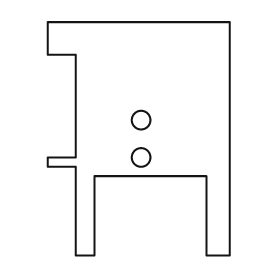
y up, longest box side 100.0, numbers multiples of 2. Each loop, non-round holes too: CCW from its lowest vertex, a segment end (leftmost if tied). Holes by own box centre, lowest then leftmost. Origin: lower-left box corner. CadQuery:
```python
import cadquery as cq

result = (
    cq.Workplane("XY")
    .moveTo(12.0, 0.0)
    .lineTo(20.0, 0.0)
    .lineTo(20.0, 34.0)
    .lineTo(68.0, 34.0)
    .lineTo(68.0, 0.0)
    .lineTo(78.0, 0.0)
    .lineTo(78.0, 100.0)
    .lineTo(0.0, 100.0)
    .lineTo(0.0, 86.0)
    .lineTo(12.0, 86.0)
    .lineTo(12.0, 42.0)
    .lineTo(0.0, 42.0)
    .lineTo(0.0, 38.0)
    .lineTo(12.0, 38.0)
    .close()
    .moveTo(40.0, 42.0)
    .circle(4.0)
    .moveTo(40.0, 58.0)
    .circle(4.0)
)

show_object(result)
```